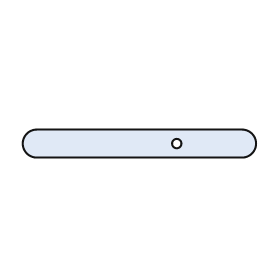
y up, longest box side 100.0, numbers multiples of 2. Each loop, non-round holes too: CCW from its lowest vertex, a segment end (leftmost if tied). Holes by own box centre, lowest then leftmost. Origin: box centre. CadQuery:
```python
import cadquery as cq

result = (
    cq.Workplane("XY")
    .moveTo(-44.0, -6.0)
    .lineTo(44.0, -6.0)
    .threePointArc((50.0, 0.0), (44.0, 6.0))
    .lineTo(-44.0, 6.0)
    .threePointArc((-50.0, 0.0), (-44.0, -6.0))
    .close()
    .moveTo(16.0, 0.0)
    .circle(2.0)
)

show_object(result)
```